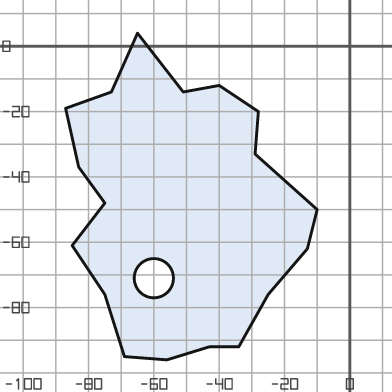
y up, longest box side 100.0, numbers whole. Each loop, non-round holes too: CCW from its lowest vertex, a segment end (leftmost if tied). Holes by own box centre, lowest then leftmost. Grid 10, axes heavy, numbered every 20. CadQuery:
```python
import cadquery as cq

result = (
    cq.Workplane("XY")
    .moveTo(-56.0, -96.0)
    .lineTo(-43.0, -92.0)
    .lineTo(-34.0, -92.0)
    .lineTo(-25.0, -76.0)
    .lineTo(-13.0, -62.0)
    .lineTo(-10.0, -50.0)
    .lineTo(-29.0, -33.0)
    .lineTo(-28.0, -20.0)
    .lineTo(-40.0, -12.0)
    .lineTo(-51.0, -14.0)
    .lineTo(-65.0, 4.0)
    .lineTo(-73.0, -14.0)
    .lineTo(-87.0, -19.0)
    .lineTo(-83.0, -37.0)
    .lineTo(-75.0, -48.0)
    .lineTo(-85.0, -61.0)
    .lineTo(-75.0, -76.0)
    .lineTo(-69.0, -95.0)
    .close()
    .moveTo(-60.0, -71.0)
    .circle(6.0)
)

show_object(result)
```